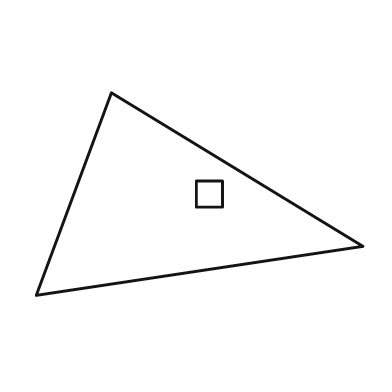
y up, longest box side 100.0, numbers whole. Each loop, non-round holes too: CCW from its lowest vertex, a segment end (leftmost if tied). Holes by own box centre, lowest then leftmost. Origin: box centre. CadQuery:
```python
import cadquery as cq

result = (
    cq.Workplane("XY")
    .moveTo(-50.0, -31.0)
    .lineTo(50.0, -16.0)
    .lineTo(-27.0, 31.0)
    .close()
    .moveTo(-1.0, -4.0)
    .lineTo(7.0, -4.0)
    .lineTo(7.0, 4.0)
    .lineTo(-1.0, 4.0)
    .close()
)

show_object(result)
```